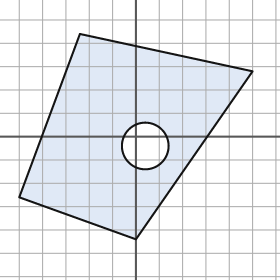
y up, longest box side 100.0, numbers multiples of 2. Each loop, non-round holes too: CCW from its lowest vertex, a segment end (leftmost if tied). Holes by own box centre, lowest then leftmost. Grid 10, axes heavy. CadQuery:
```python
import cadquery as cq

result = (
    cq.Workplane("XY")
    .moveTo(0.0, -44.0)
    .lineTo(50.0, 28.0)
    .lineTo(-24.0, 44.0)
    .lineTo(-50.0, -26.0)
    .close()
    .moveTo(4.0, -4.0)
    .circle(10.0)
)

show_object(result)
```